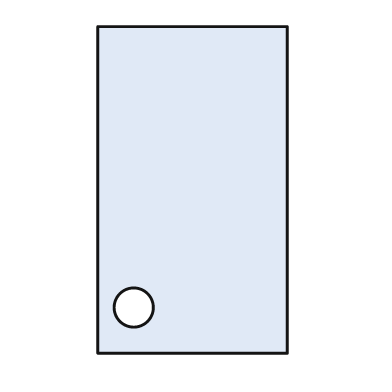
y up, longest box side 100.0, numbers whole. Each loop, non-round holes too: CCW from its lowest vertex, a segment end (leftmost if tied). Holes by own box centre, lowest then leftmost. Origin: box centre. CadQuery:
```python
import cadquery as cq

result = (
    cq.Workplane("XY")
    .moveTo(-29.0, -50.0)
    .lineTo(29.0, -50.0)
    .lineTo(29.0, 50.0)
    .lineTo(-29.0, 50.0)
    .close()
    .moveTo(-18.0, -36.0)
    .circle(6.0)
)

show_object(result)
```